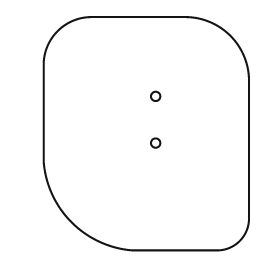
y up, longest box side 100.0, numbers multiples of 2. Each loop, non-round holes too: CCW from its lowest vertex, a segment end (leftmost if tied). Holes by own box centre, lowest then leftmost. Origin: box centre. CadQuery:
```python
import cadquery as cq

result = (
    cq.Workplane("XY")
    .moveTo(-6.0, -50.0)
    .lineTo(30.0, -50.0)
    .threePointArc((40.0, -46.0), (44.0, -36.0))
    .lineTo(44.0, 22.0)
    .threePointArc((36.0, 42.0), (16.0, 50.0))
    .lineTo(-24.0, 50.0)
    .threePointArc((-38.0, 44.0), (-44.0, 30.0))
    .lineTo(-44.0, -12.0)
    .threePointArc((-32.0, -38.0), (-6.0, -50.0))
    .close()
    .moveTo(4.0, -4.0)
    .circle(2.0)
    .moveTo(4.0, 16.0)
    .circle(2.0)
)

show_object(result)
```